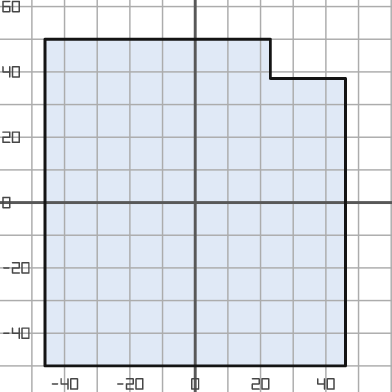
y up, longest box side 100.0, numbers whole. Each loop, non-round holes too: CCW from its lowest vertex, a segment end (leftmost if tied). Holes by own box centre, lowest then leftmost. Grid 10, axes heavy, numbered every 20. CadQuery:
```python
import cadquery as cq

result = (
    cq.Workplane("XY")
    .moveTo(-46.0, -50.0)
    .lineTo(46.0, -50.0)
    .lineTo(46.0, 38.0)
    .lineTo(23.0, 38.0)
    .lineTo(23.0, 50.0)
    .lineTo(-46.0, 50.0)
    .close()
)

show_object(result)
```